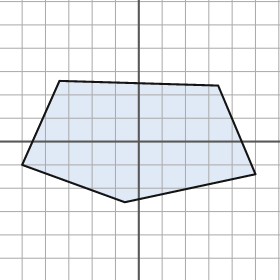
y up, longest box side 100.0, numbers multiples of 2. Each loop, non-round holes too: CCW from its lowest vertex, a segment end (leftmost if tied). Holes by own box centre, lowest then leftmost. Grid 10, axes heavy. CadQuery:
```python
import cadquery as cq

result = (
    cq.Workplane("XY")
    .moveTo(-6.0, -26.0)
    .lineTo(50.0, -14.0)
    .lineTo(34.0, 24.0)
    .lineTo(-34.0, 26.0)
    .lineTo(-50.0, -10.0)
    .close()
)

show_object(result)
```